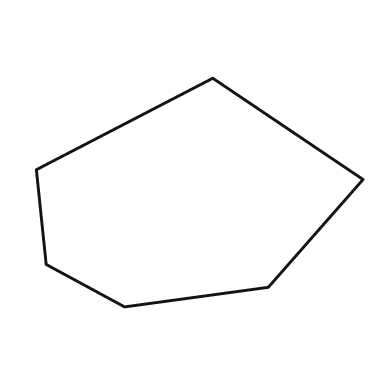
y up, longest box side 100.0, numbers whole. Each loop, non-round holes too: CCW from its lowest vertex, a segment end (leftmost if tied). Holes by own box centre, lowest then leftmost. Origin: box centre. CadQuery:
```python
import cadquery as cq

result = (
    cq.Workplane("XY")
    .moveTo(-23.0, -35.0)
    .lineTo(21.0, -29.0)
    .lineTo(50.0, 4.0)
    .lineTo(4.0, 35.0)
    .lineTo(-50.0, 7.0)
    .lineTo(-47.0, -22.0)
    .close()
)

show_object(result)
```